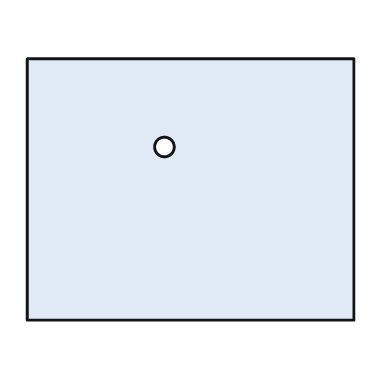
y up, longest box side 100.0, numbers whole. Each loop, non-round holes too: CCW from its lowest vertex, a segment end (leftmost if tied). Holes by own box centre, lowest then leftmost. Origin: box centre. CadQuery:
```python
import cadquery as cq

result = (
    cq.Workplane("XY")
    .moveTo(-50.0, -40.0)
    .lineTo(50.0, -40.0)
    .lineTo(50.0, 40.0)
    .lineTo(-50.0, 40.0)
    .close()
    .moveTo(-8.0, 13.0)
    .circle(3.0)
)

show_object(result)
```